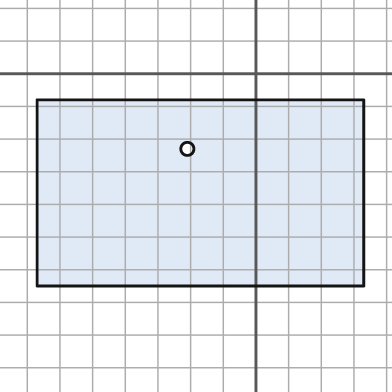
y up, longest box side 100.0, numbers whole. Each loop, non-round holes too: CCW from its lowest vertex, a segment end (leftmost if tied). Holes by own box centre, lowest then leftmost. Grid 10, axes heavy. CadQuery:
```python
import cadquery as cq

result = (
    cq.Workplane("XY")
    .moveTo(-67.0, -65.0)
    .lineTo(33.0, -65.0)
    .lineTo(33.0, -8.0)
    .lineTo(-67.0, -8.0)
    .close()
    .moveTo(-21.0, -23.0)
    .circle(2.0)
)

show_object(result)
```